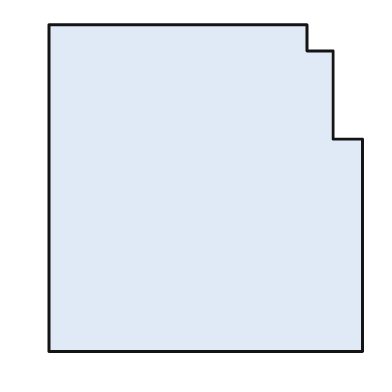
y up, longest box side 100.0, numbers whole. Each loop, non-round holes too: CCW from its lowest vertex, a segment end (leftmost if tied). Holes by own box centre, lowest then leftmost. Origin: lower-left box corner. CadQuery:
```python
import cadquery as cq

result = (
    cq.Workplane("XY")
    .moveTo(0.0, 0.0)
    .lineTo(96.0, 0.0)
    .lineTo(96.0, 65.0)
    .lineTo(87.0, 65.0)
    .lineTo(87.0, 92.0)
    .lineTo(79.0, 92.0)
    .lineTo(79.0, 100.0)
    .lineTo(0.0, 100.0)
    .close()
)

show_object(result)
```